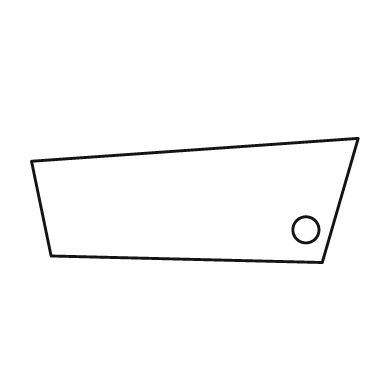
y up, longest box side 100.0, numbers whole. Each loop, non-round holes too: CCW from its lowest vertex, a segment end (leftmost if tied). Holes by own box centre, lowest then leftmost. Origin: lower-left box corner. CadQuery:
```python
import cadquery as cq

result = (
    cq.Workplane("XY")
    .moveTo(89.0, 0.0)
    .lineTo(100.0, 38.0)
    .lineTo(0.0, 31.0)
    .lineTo(6.0, 2.0)
    .close()
    .moveTo(84.0, 10.0)
    .circle(4.0)
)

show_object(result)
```